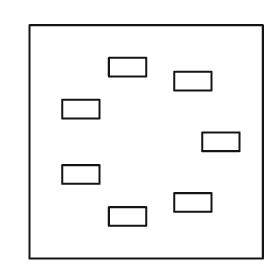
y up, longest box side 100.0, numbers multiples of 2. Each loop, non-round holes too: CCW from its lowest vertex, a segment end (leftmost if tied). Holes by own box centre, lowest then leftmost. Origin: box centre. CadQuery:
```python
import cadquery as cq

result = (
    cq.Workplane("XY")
    .moveTo(-50.0, -50.0)
    .lineTo(50.0, -50.0)
    .lineTo(50.0, 50.0)
    .lineTo(-50.0, 50.0)
    .close()
    .moveTo(-16.0, -36.0)
    .lineTo(0.0, -36.0)
    .lineTo(0.0, -28.0)
    .lineTo(-16.0, -28.0)
    .close()
    .moveTo(12.0, -30.0)
    .lineTo(28.0, -30.0)
    .lineTo(28.0, -22.0)
    .lineTo(12.0, -22.0)
    .close()
    .moveTo(-36.0, -18.0)
    .lineTo(-20.0, -18.0)
    .lineTo(-20.0, -10.0)
    .lineTo(-36.0, -10.0)
    .close()
    .moveTo(24.0, -4.0)
    .lineTo(40.0, -4.0)
    .lineTo(40.0, 4.0)
    .lineTo(24.0, 4.0)
    .close()
    .moveTo(-36.0, 10.0)
    .lineTo(-20.0, 10.0)
    .lineTo(-20.0, 18.0)
    .lineTo(-36.0, 18.0)
    .close()
    .moveTo(12.0, 22.0)
    .lineTo(28.0, 22.0)
    .lineTo(28.0, 30.0)
    .lineTo(12.0, 30.0)
    .close()
    .moveTo(-16.0, 28.0)
    .lineTo(0.0, 28.0)
    .lineTo(0.0, 36.0)
    .lineTo(-16.0, 36.0)
    .close()
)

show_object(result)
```